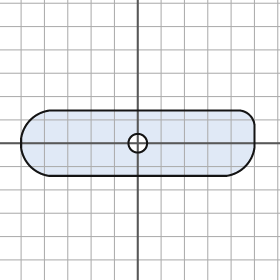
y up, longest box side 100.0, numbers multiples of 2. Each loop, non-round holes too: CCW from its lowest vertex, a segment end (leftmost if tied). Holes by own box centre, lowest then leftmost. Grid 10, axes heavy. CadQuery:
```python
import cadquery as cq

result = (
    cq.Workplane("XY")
    .moveTo(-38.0, -14.0)
    .lineTo(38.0, -14.0)
    .threePointArc((46.0, -10.0), (50.0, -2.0))
    .lineTo(50.0, 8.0)
    .threePointArc((48.0, 12.0), (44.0, 14.0))
    .lineTo(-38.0, 14.0)
    .threePointArc((-46.0, 10.0), (-50.0, 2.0))
    .lineTo(-50.0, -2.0)
    .threePointArc((-46.0, -10.0), (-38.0, -14.0))
    .close()
    .moveTo(0.0, 0.0)
    .circle(4.0)
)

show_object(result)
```